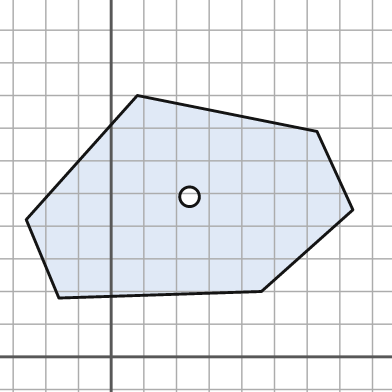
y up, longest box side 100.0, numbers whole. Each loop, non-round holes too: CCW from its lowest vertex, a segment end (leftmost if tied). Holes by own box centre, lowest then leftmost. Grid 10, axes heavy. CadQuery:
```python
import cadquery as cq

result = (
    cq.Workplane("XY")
    .moveTo(-16.0, 18.0)
    .lineTo(46.0, 20.0)
    .lineTo(74.0, 45.0)
    .lineTo(63.0, 69.0)
    .lineTo(8.0, 80.0)
    .lineTo(-26.0, 42.0)
    .close()
    .moveTo(24.0, 49.0)
    .circle(3.0)
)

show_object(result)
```